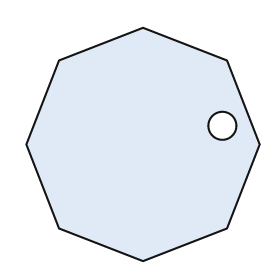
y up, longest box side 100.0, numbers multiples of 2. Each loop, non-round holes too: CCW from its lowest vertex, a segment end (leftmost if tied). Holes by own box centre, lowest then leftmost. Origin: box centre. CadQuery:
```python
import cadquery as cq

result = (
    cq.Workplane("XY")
    .moveTo(0.0, -50.0)
    .lineTo(36.0, -36.0)
    .lineTo(50.0, 0.0)
    .lineTo(36.0, 36.0)
    .lineTo(0.0, 50.0)
    .lineTo(-36.0, 36.0)
    .lineTo(-50.0, 0.0)
    .lineTo(-36.0, -36.0)
    .close()
    .moveTo(34.0, 8.0)
    .circle(6.0)
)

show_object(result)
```